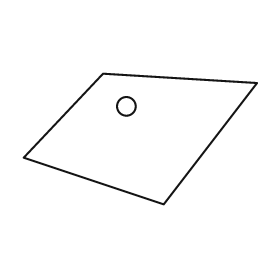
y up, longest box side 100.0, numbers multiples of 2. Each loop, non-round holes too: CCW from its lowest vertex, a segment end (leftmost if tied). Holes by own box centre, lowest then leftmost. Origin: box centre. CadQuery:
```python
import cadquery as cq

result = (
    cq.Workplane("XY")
    .moveTo(10.0, -28.0)
    .lineTo(50.0, 24.0)
    .lineTo(-16.0, 28.0)
    .lineTo(-50.0, -8.0)
    .close()
    .moveTo(-6.0, 14.0)
    .circle(4.0)
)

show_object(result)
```